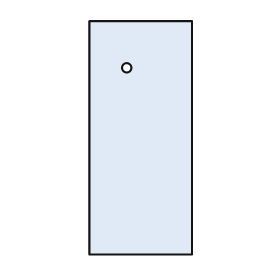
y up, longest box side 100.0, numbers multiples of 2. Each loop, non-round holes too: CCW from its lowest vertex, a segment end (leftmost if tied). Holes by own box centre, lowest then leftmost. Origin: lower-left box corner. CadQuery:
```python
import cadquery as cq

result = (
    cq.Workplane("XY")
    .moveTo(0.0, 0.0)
    .lineTo(44.0, 0.0)
    .lineTo(44.0, 100.0)
    .lineTo(0.0, 100.0)
    .close()
    .moveTo(16.0, 80.0)
    .circle(2.0)
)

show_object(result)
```